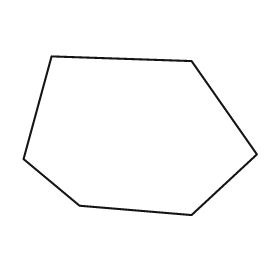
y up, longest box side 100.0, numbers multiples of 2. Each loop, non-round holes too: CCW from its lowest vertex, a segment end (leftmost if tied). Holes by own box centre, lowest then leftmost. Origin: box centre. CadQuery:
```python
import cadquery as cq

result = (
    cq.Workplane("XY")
    .moveTo(22.0, -34.0)
    .lineTo(50.0, -8.0)
    .lineTo(22.0, 32.0)
    .lineTo(-38.0, 34.0)
    .lineTo(-50.0, -10.0)
    .lineTo(-26.0, -30.0)
    .close()
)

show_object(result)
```